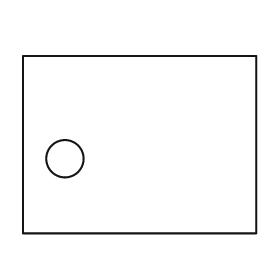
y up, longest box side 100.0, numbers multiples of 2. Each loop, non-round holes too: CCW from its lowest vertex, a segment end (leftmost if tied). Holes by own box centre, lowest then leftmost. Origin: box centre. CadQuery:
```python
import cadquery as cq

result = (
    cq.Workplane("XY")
    .moveTo(-50.0, -38.0)
    .lineTo(50.0, -38.0)
    .lineTo(50.0, 38.0)
    .lineTo(-50.0, 38.0)
    .close()
    .moveTo(-32.0, -6.0)
    .circle(8.0)
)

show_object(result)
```